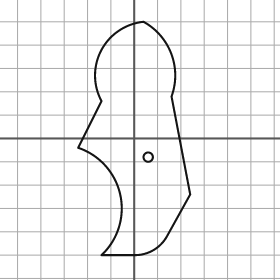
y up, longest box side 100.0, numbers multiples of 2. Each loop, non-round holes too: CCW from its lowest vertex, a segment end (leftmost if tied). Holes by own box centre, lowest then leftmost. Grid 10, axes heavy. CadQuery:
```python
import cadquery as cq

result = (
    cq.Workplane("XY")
    .moveTo(-14.0, -50.0)
    .lineTo(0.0, -50.0)
    .threePointArc((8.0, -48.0), (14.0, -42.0))
    .lineTo(24.0, -24.0)
    .lineTo(16.0, 18.0)
    .threePointArc((16.0, 36.0), (4.0, 50.0))
    .threePointArc((-14.0, 38.0), (-14.0, 16.0))
    .lineTo(-24.0, -4.0)
    .threePointArc((-6.0, -24.0), (-14.0, -50.0))
    .close()
    .moveTo(6.0, -8.0)
    .circle(2.0)
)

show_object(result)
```